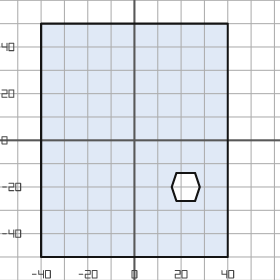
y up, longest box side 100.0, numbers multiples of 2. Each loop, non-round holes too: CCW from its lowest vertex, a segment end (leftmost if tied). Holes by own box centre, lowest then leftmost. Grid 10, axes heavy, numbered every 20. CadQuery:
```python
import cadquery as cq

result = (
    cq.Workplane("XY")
    .moveTo(-40.0, -50.0)
    .lineTo(40.0, -50.0)
    .lineTo(40.0, 50.0)
    .lineTo(-40.0, 50.0)
    .close()
    .moveTo(18.0, -26.0)
    .lineTo(26.0, -26.0)
    .lineTo(28.0, -20.0)
    .lineTo(26.0, -14.0)
    .lineTo(18.0, -14.0)
    .lineTo(16.0, -20.0)
    .close()
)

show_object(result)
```